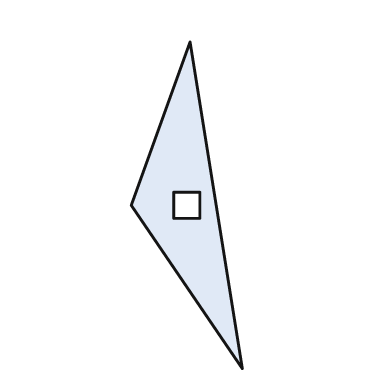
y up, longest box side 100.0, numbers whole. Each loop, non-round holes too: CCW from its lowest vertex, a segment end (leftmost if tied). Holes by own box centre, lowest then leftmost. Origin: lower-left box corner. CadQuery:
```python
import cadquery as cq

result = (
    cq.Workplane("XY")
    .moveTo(34.0, 0.0)
    .lineTo(18.0, 100.0)
    .lineTo(0.0, 50.0)
    .close()
    .moveTo(13.0, 46.0)
    .lineTo(21.0, 46.0)
    .lineTo(21.0, 54.0)
    .lineTo(13.0, 54.0)
    .close()
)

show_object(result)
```